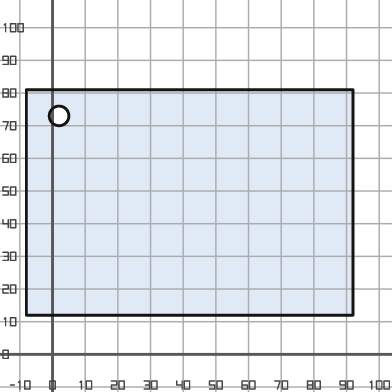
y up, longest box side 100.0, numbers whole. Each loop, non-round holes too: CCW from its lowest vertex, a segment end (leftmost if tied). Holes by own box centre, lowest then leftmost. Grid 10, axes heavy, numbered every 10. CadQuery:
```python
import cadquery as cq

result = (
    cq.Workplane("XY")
    .moveTo(-8.0, 12.0)
    .lineTo(92.0, 12.0)
    .lineTo(92.0, 81.0)
    .lineTo(-8.0, 81.0)
    .close()
    .moveTo(2.0, 73.0)
    .circle(3.0)
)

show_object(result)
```